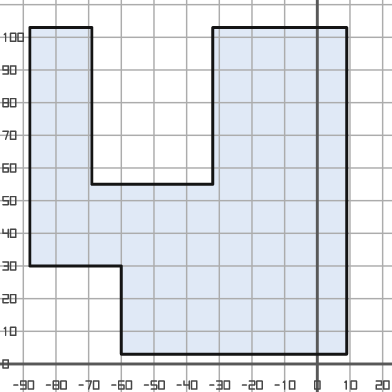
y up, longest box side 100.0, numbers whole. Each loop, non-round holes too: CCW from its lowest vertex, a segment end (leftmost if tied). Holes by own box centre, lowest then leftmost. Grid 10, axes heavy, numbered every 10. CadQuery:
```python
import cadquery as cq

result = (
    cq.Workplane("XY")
    .moveTo(-60.0, 3.0)
    .lineTo(9.0, 3.0)
    .lineTo(9.0, 103.0)
    .lineTo(-32.0, 103.0)
    .lineTo(-32.0, 55.0)
    .lineTo(-69.0, 55.0)
    .lineTo(-69.0, 103.0)
    .lineTo(-88.0, 103.0)
    .lineTo(-88.0, 30.0)
    .lineTo(-60.0, 30.0)
    .close()
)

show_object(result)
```